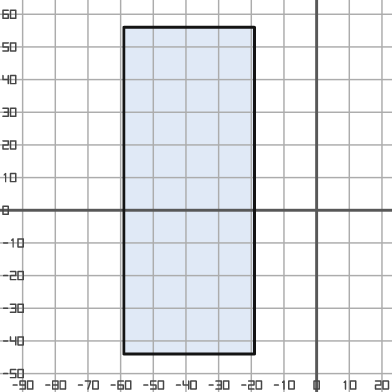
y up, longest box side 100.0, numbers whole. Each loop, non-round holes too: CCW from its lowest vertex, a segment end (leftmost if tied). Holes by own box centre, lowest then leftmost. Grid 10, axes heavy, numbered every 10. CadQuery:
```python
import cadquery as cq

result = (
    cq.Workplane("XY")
    .moveTo(-59.0, -44.0)
    .lineTo(-19.0, -44.0)
    .lineTo(-19.0, 56.0)
    .lineTo(-59.0, 56.0)
    .close()
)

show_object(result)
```